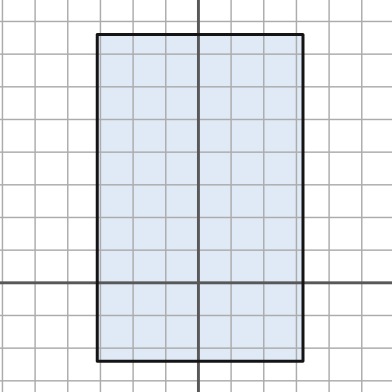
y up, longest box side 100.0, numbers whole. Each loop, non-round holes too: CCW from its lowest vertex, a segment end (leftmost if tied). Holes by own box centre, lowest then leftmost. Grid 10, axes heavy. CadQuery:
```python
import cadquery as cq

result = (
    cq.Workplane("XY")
    .moveTo(-31.0, -24.0)
    .lineTo(32.0, -24.0)
    .lineTo(32.0, 76.0)
    .lineTo(-31.0, 76.0)
    .close()
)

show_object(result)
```